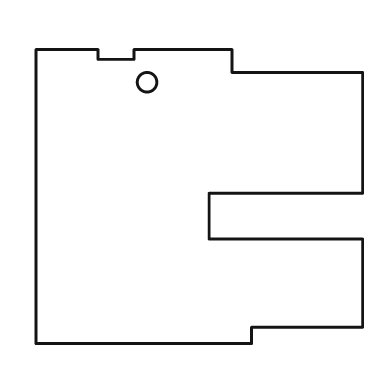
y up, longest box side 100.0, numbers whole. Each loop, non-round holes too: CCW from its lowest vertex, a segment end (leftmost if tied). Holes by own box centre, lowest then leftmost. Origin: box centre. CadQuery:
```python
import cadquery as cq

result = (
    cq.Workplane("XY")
    .moveTo(-50.0, -45.0)
    .lineTo(16.0, -45.0)
    .lineTo(16.0, -40.0)
    .lineTo(50.0, -40.0)
    .lineTo(50.0, -13.0)
    .lineTo(3.0, -13.0)
    .lineTo(3.0, 1.0)
    .lineTo(50.0, 1.0)
    .lineTo(50.0, 38.0)
    .lineTo(10.0, 38.0)
    .lineTo(10.0, 45.0)
    .lineTo(-20.0, 45.0)
    .lineTo(-20.0, 42.0)
    .lineTo(-31.0, 42.0)
    .lineTo(-31.0, 45.0)
    .lineTo(-50.0, 45.0)
    .close()
    .moveTo(-16.0, 35.0)
    .circle(3.0)
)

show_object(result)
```